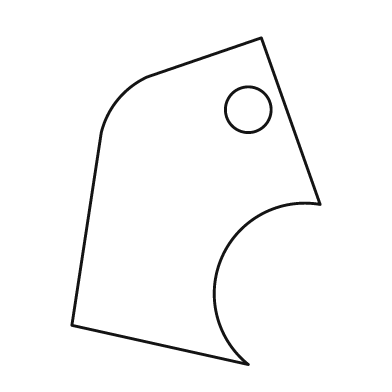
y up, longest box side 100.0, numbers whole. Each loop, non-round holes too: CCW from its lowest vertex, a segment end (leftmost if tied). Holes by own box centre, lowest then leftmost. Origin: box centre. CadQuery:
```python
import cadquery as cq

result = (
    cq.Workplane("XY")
    .moveTo(16.0, -50.0)
    .threePointArc((8.0, -17.0), (38.0, -1.0))
    .lineTo(20.0, 50.0)
    .lineTo(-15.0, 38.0)
    .threePointArc((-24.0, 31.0), (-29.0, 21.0))
    .lineTo(-38.0, -38.0)
    .close()
    .moveTo(16.0, 28.0)
    .circle(7.0)
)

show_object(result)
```